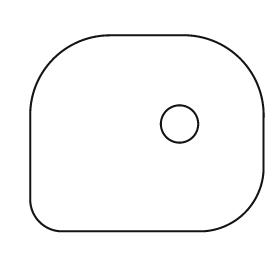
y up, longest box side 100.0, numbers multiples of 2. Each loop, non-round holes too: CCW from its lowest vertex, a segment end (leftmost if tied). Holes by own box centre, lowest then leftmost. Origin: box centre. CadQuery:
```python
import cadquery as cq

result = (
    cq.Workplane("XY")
    .moveTo(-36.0, -42.0)
    .lineTo(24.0, -42.0)
    .threePointArc((42.0, -34.0), (50.0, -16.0))
    .lineTo(50.0, 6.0)
    .threePointArc((40.0, 32.0), (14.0, 42.0))
    .lineTo(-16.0, 42.0)
    .threePointArc((-40.0, 32.0), (-50.0, 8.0))
    .lineTo(-50.0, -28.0)
    .threePointArc((-46.0, -38.0), (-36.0, -42.0))
    .close()
    .moveTo(14.0, 4.0)
    .circle(8.0)
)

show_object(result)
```